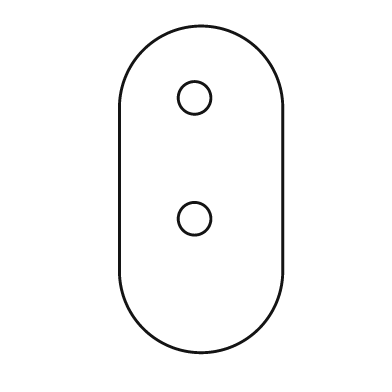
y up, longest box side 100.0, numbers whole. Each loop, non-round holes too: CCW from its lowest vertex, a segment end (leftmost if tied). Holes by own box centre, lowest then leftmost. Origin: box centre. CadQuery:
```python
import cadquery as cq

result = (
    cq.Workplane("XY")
    .moveTo(-25.0, -25.0)
    .threePointArc((0.0, -50.0), (25.0, -25.0))
    .lineTo(25.0, 25.0)
    .threePointArc((0.0, 50.0), (-25.0, 25.0))
    .close()
    .moveTo(-2.0, -9.0)
    .circle(5.0)
    .moveTo(-2.0, 28.0)
    .circle(5.0)
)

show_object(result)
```